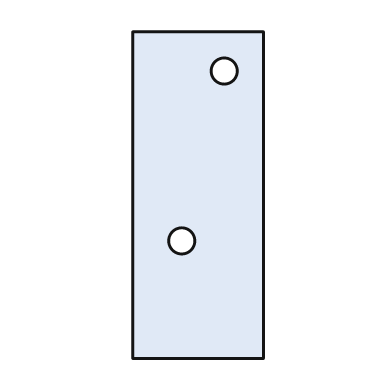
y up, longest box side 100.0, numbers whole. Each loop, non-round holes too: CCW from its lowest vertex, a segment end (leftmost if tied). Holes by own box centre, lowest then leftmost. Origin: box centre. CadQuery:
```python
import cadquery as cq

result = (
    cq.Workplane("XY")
    .moveTo(-20.0, -50.0)
    .lineTo(20.0, -50.0)
    .lineTo(20.0, 50.0)
    .lineTo(-20.0, 50.0)
    .close()
    .moveTo(-5.0, -14.0)
    .circle(4.0)
    .moveTo(8.0, 38.0)
    .circle(4.0)
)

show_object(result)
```